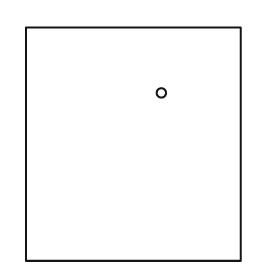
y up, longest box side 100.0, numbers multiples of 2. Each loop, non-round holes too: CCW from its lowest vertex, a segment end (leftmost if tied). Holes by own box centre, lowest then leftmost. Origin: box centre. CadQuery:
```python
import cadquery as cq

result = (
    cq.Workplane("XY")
    .moveTo(-46.0, -50.0)
    .lineTo(46.0, -50.0)
    .lineTo(46.0, 50.0)
    .lineTo(-46.0, 50.0)
    .close()
    .moveTo(12.0, 22.0)
    .circle(2.0)
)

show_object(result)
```